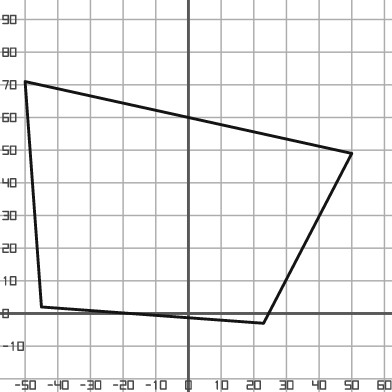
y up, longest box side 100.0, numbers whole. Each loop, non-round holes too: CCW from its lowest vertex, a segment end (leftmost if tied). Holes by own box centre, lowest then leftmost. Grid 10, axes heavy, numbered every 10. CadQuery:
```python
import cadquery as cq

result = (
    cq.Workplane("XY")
    .moveTo(23.0, -3.0)
    .lineTo(50.0, 49.0)
    .lineTo(-50.0, 71.0)
    .lineTo(-45.0, 2.0)
    .close()
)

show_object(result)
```